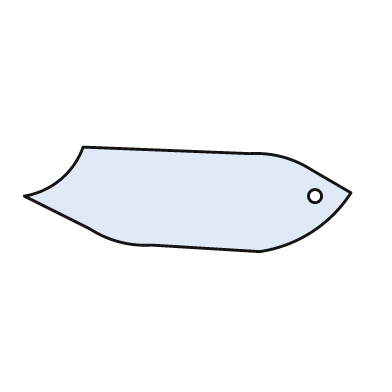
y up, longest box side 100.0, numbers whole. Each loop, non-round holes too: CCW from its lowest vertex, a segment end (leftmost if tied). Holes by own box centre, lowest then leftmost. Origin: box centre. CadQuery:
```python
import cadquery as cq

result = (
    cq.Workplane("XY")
    .moveTo(22.0, -16.0)
    .threePointArc((38.0, -10.0), (50.0, 2.0))
    .lineTo(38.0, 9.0)
    .threePointArc((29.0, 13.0), (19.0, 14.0))
    .lineTo(-32.0, 16.0)
    .threePointArc((-39.0, 6.0), (-50.0, 1.0))
    .lineTo(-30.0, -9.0)
    .threePointArc((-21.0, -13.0), (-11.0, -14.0))
    .close()
    .moveTo(39.0, 1.0)
    .circle(2.0)
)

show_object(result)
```